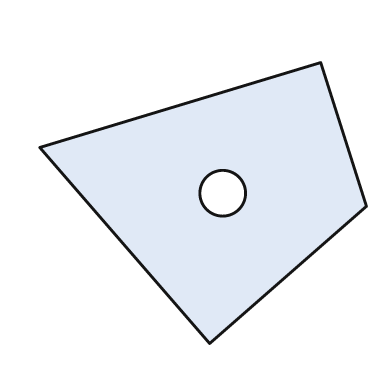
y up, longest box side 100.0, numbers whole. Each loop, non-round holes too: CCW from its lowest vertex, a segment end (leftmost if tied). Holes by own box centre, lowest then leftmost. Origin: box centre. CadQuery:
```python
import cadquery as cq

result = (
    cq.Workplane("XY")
    .moveTo(2.0, -43.0)
    .lineTo(50.0, -1.0)
    .lineTo(36.0, 43.0)
    .lineTo(-50.0, 17.0)
    .close()
    .moveTo(6.0, 3.0)
    .circle(7.0)
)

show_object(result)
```